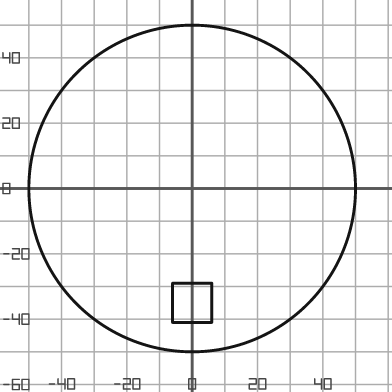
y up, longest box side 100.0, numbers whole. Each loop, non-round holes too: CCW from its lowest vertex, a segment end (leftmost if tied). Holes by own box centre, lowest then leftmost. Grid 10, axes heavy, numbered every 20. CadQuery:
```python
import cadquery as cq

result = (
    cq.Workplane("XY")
    .moveTo(0.0, 0.0)
    .circle(50.0)
    .moveTo(-6.0, -41.0)
    .lineTo(6.0, -41.0)
    .lineTo(6.0, -29.0)
    .lineTo(-6.0, -29.0)
    .close()
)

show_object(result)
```